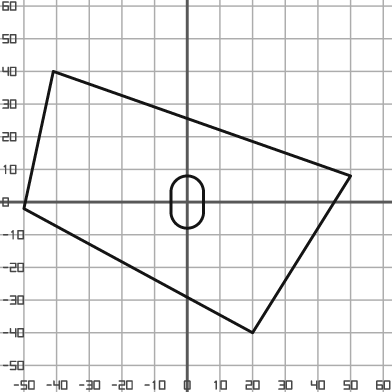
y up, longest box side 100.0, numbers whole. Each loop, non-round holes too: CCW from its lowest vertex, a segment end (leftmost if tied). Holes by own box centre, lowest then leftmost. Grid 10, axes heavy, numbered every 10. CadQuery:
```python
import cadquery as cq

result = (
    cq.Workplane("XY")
    .moveTo(20.0, -40.0)
    .lineTo(50.0, 8.0)
    .lineTo(-41.0, 40.0)
    .lineTo(-50.0, -2.0)
    .close()
    .moveTo(-5.0, -3.0)
    .threePointArc((0.0, -8.0), (5.0, -3.0))
    .lineTo(5.0, 3.0)
    .threePointArc((0.0, 8.0), (-5.0, 3.0))
    .close()
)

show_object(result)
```